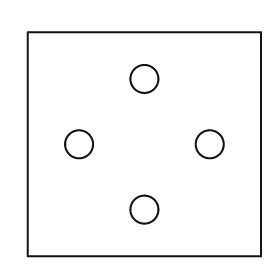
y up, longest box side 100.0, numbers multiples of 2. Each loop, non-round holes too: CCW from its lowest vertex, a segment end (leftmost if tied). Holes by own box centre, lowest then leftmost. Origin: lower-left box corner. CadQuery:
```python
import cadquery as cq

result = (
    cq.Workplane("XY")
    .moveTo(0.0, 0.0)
    .lineTo(100.0, 0.0)
    .lineTo(100.0, 96.0)
    .lineTo(0.0, 96.0)
    .close()
    .moveTo(50.0, 20.0)
    .circle(6.0)
    .moveTo(22.0, 48.0)
    .circle(6.0)
    .moveTo(78.0, 48.0)
    .circle(6.0)
    .moveTo(50.0, 76.0)
    .circle(6.0)
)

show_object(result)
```